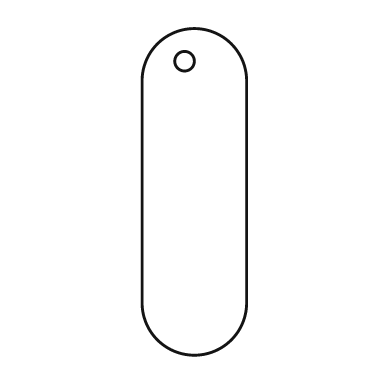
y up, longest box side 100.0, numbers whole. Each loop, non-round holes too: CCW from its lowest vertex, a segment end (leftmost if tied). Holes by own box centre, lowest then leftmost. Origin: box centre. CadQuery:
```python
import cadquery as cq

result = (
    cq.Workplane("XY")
    .moveTo(-16.0, -34.0)
    .threePointArc((0.0, -50.0), (16.0, -34.0))
    .lineTo(16.0, 34.0)
    .threePointArc((0.0, 50.0), (-16.0, 34.0))
    .close()
    .moveTo(-3.0, 40.0)
    .circle(3.0)
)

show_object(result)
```